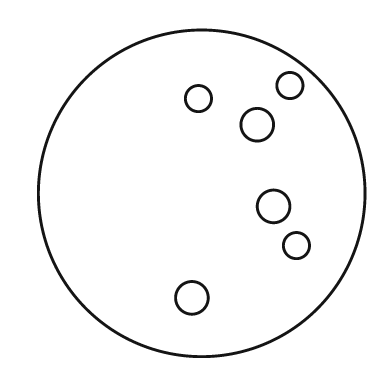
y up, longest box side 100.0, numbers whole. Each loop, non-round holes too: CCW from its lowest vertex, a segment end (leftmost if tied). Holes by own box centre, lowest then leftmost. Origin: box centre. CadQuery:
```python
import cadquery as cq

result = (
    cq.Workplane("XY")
    .moveTo(0.0, 0.0)
    .circle(50.0)
    .moveTo(-3.0, -32.0)
    .circle(5.0)
    .moveTo(29.0, -16.0)
    .circle(4.0)
    .moveTo(22.0, -4.0)
    .circle(5.0)
    .moveTo(17.0, 21.0)
    .circle(5.0)
    .moveTo(-1.0, 29.0)
    .circle(4.0)
    .moveTo(27.0, 33.0)
    .circle(4.0)
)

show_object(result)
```